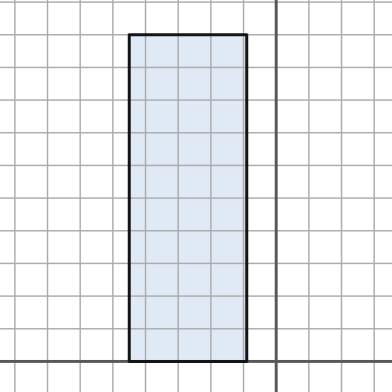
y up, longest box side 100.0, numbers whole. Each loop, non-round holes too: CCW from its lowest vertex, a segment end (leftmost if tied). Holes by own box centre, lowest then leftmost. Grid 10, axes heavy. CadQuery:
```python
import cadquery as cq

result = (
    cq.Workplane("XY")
    .moveTo(-45.0, 0.0)
    .lineTo(-9.0, 0.0)
    .lineTo(-9.0, 100.0)
    .lineTo(-45.0, 100.0)
    .close()
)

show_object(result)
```